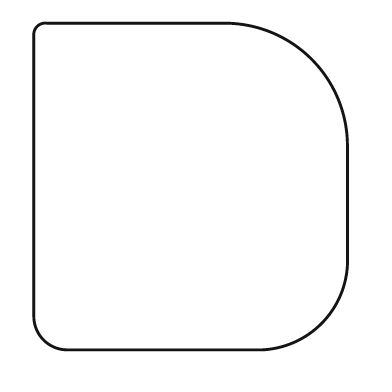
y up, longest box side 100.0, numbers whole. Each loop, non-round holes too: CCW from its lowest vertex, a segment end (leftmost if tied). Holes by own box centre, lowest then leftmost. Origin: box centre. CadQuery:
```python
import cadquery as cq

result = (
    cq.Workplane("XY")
    .moveTo(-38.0, -50.0)
    .lineTo(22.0, -50.0)
    .threePointArc((40.0, -42.0), (48.0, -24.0))
    .lineTo(48.0, 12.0)
    .threePointArc((37.0, 39.0), (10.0, 50.0))
    .lineTo(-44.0, 50.0)
    .threePointArc((-47.0, 49.0), (-48.0, 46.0))
    .lineTo(-48.0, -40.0)
    .threePointArc((-45.0, -47.0), (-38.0, -50.0))
    .close()
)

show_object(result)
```